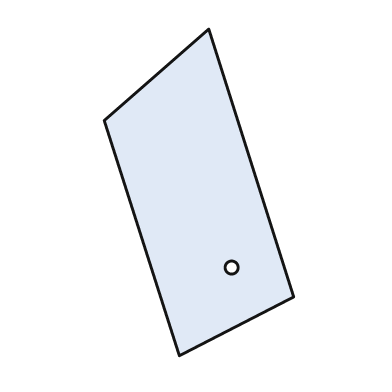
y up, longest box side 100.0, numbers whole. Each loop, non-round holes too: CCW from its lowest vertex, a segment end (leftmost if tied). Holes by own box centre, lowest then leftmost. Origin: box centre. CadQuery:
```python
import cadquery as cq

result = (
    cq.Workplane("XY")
    .moveTo(-6.0, -50.0)
    .lineTo(29.0, -32.0)
    .lineTo(3.0, 50.0)
    .lineTo(-29.0, 22.0)
    .close()
    .moveTo(10.0, -23.0)
    .circle(2.0)
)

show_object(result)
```